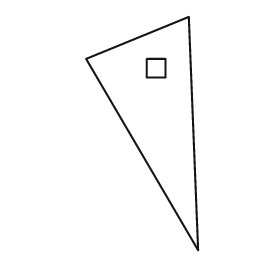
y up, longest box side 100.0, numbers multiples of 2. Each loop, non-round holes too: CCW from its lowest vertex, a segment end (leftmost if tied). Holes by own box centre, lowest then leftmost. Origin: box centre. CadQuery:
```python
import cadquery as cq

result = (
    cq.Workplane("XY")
    .moveTo(24.0, -50.0)
    .lineTo(20.0, 50.0)
    .lineTo(-24.0, 32.0)
    .close()
    .moveTo(2.0, 24.0)
    .lineTo(10.0, 24.0)
    .lineTo(10.0, 32.0)
    .lineTo(2.0, 32.0)
    .close()
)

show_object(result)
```